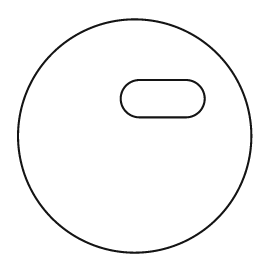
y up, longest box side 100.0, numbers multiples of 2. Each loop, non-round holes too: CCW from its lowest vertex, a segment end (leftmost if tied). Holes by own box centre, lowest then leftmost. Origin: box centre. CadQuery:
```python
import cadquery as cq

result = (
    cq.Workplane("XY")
    .moveTo(0.0, 0.0)
    .circle(50.0)
    .moveTo(2.0, 8.0)
    .lineTo(22.0, 8.0)
    .threePointArc((30.0, 16.0), (22.0, 24.0))
    .lineTo(2.0, 24.0)
    .threePointArc((-6.0, 16.0), (2.0, 8.0))
    .close()
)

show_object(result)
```